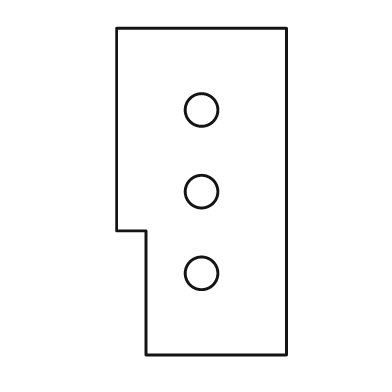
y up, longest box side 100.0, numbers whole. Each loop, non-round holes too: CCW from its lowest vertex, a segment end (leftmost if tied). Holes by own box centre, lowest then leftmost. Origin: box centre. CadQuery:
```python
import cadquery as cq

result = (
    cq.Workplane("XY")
    .moveTo(-17.0, -50.0)
    .lineTo(26.0, -50.0)
    .lineTo(26.0, 50.0)
    .lineTo(-26.0, 50.0)
    .lineTo(-26.0, -12.0)
    .lineTo(-17.0, -12.0)
    .close()
    .moveTo(0.0, -25.0)
    .circle(5.0)
    .moveTo(0.0, 0.0)
    .circle(5.0)
    .moveTo(0.0, 25.0)
    .circle(5.0)
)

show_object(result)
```